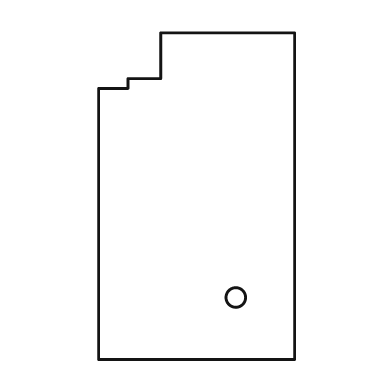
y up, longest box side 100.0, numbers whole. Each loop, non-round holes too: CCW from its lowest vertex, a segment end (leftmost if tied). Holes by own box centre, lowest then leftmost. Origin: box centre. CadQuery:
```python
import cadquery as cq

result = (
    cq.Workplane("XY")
    .moveTo(-30.0, -50.0)
    .lineTo(30.0, -50.0)
    .lineTo(30.0, 50.0)
    .lineTo(-11.0, 50.0)
    .lineTo(-11.0, 36.0)
    .lineTo(-21.0, 36.0)
    .lineTo(-21.0, 33.0)
    .lineTo(-30.0, 33.0)
    .close()
    .moveTo(12.0, -31.0)
    .circle(3.0)
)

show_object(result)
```